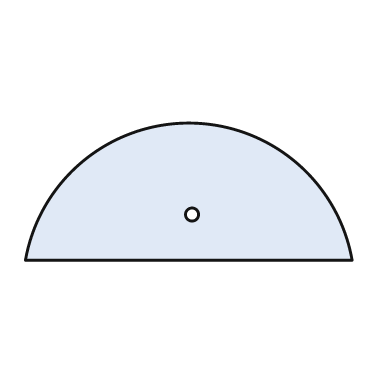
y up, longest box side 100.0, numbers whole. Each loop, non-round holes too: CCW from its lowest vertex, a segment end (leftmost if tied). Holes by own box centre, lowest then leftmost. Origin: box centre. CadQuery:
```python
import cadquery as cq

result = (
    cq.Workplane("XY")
    .moveTo(-50.0, -21.0)
    .lineTo(50.0, -21.0)
    .threePointArc((0.0, 21.0), (-50.0, -21.0))
    .close()
    .moveTo(1.0, -7.0)
    .circle(2.0)
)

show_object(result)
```